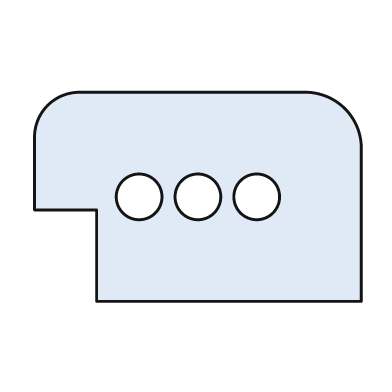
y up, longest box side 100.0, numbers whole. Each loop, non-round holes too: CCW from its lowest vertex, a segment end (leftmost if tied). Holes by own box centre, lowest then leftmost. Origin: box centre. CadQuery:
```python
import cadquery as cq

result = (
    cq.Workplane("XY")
    .moveTo(-31.0, -32.0)
    .lineTo(50.0, -32.0)
    .lineTo(50.0, 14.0)
    .threePointArc((45.0, 27.0), (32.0, 32.0))
    .lineTo(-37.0, 32.0)
    .threePointArc((-46.0, 28.0), (-50.0, 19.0))
    .lineTo(-50.0, -4.0)
    .lineTo(-31.0, -4.0)
    .close()
    .moveTo(-18.0, 0.0)
    .circle(7.0)
    .moveTo(0.0, 0.0)
    .circle(7.0)
    .moveTo(18.0, 0.0)
    .circle(7.0)
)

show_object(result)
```